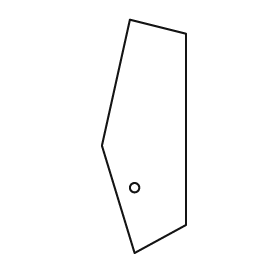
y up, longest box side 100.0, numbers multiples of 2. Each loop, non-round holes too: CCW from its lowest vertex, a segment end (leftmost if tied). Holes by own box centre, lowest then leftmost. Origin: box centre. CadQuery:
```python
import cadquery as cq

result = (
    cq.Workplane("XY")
    .moveTo(-4.0, -50.0)
    .lineTo(18.0, -38.0)
    .lineTo(18.0, 44.0)
    .lineTo(-6.0, 50.0)
    .lineTo(-18.0, -4.0)
    .close()
    .moveTo(-4.0, -22.0)
    .circle(2.0)
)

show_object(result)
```